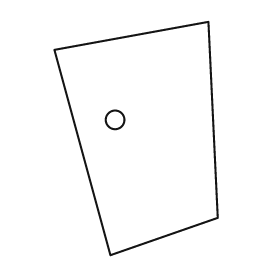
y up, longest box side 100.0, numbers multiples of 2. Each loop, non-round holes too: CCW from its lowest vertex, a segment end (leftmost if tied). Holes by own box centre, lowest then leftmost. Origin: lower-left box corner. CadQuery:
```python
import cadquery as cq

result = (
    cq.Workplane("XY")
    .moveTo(24.0, 0.0)
    .lineTo(70.0, 16.0)
    .lineTo(66.0, 100.0)
    .lineTo(0.0, 88.0)
    .close()
    .moveTo(26.0, 58.0)
    .circle(4.0)
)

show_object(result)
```